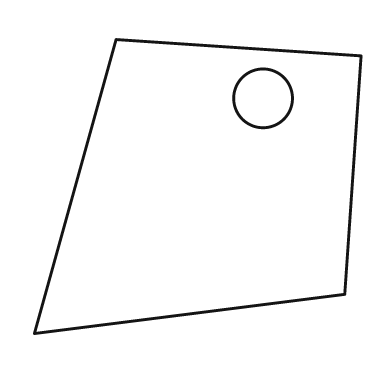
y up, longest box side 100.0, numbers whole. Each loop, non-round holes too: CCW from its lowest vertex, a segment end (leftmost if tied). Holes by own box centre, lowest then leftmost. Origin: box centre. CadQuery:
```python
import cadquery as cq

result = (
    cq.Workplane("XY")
    .moveTo(-50.0, -45.0)
    .lineTo(45.0, -33.0)
    .lineTo(50.0, 40.0)
    .lineTo(-25.0, 45.0)
    .close()
    .moveTo(20.0, 27.0)
    .circle(9.0)
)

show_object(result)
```